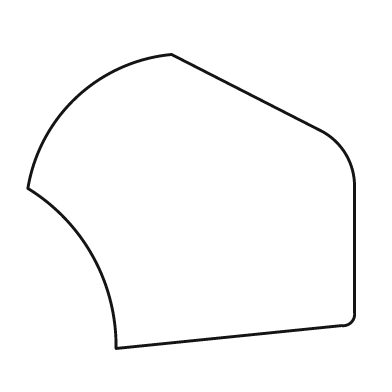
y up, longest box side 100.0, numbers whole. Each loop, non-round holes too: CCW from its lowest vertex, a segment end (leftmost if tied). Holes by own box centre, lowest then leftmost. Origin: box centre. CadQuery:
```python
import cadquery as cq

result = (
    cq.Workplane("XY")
    .moveTo(-23.0, -45.0)
    .lineTo(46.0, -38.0)
    .threePointArc((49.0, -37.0), (50.0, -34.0))
    .lineTo(50.0, 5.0)
    .threePointArc((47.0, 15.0), (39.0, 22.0))
    .lineTo(-6.0, 45.0)
    .threePointArc((-35.0, 32.0), (-50.0, 4.0))
    .threePointArc((-30.0, -17.0), (-23.0, -45.0))
    .close()
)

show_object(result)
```